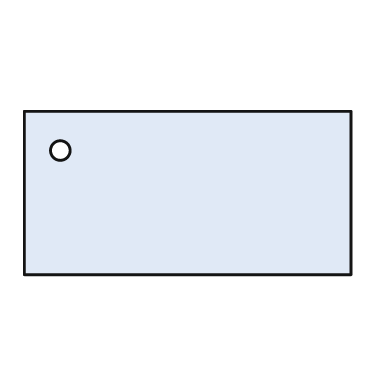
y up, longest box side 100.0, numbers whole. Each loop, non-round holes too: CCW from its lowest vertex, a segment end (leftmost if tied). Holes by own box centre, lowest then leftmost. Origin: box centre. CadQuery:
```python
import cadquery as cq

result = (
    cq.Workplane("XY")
    .moveTo(-50.0, -25.0)
    .lineTo(50.0, -25.0)
    .lineTo(50.0, 25.0)
    .lineTo(-50.0, 25.0)
    .close()
    .moveTo(-39.0, 13.0)
    .circle(3.0)
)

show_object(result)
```